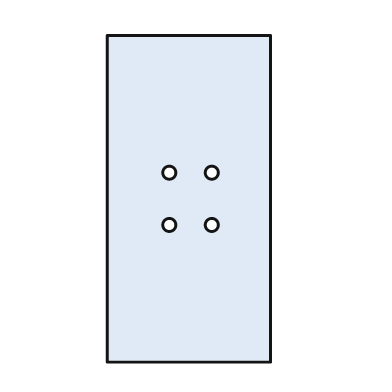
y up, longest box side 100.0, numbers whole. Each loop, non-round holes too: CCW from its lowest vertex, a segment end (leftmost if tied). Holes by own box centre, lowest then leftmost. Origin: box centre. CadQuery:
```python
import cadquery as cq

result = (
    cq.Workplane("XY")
    .moveTo(-25.0, -50.0)
    .lineTo(25.0, -50.0)
    .lineTo(25.0, 50.0)
    .lineTo(-25.0, 50.0)
    .close()
    .moveTo(-6.0, -8.0)
    .circle(2.0)
    .moveTo(7.0, -8.0)
    .circle(2.0)
    .moveTo(-6.0, 8.0)
    .circle(2.0)
    .moveTo(7.0, 8.0)
    .circle(2.0)
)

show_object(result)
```